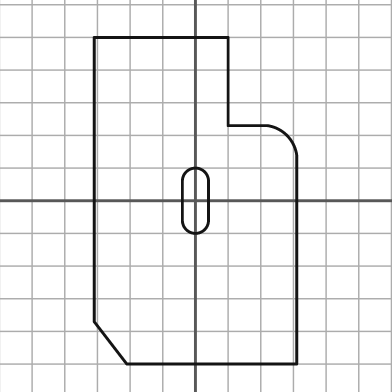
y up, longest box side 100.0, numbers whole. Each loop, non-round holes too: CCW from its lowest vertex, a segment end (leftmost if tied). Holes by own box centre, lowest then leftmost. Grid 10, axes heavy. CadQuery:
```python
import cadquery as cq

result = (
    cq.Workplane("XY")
    .moveTo(-21.0, -50.0)
    .lineTo(31.0, -50.0)
    .lineTo(31.0, 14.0)
    .threePointArc((28.0, 20.0), (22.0, 23.0))
    .lineTo(10.0, 23.0)
    .lineTo(10.0, 50.0)
    .lineTo(-31.0, 50.0)
    .lineTo(-31.0, -37.0)
    .close()
    .moveTo(-4.0, -6.0)
    .threePointArc((0.0, -10.0), (4.0, -6.0))
    .lineTo(4.0, 6.0)
    .threePointArc((0.0, 10.0), (-4.0, 6.0))
    .close()
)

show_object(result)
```